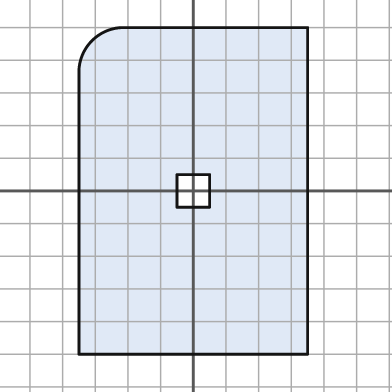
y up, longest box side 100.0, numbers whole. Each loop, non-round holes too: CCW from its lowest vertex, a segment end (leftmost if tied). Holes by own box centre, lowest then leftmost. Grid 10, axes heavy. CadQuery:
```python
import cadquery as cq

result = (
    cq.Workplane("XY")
    .moveTo(-35.0, -50.0)
    .lineTo(35.0, -50.0)
    .lineTo(35.0, 50.0)
    .lineTo(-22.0, 50.0)
    .threePointArc((-31.0, 46.0), (-35.0, 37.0))
    .close()
    .moveTo(-5.0, -5.0)
    .lineTo(5.0, -5.0)
    .lineTo(5.0, 5.0)
    .lineTo(-5.0, 5.0)
    .close()
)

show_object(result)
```